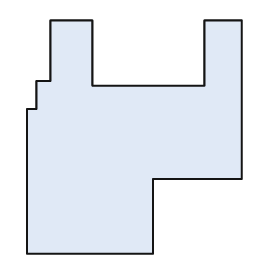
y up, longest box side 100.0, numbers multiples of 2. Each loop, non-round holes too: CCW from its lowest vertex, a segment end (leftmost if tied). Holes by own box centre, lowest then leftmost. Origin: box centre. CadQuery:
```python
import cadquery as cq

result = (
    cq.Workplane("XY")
    .moveTo(-46.0, -50.0)
    .lineTo(8.0, -50.0)
    .lineTo(8.0, -18.0)
    .lineTo(46.0, -18.0)
    .lineTo(46.0, 50.0)
    .lineTo(30.0, 50.0)
    .lineTo(30.0, 22.0)
    .lineTo(-18.0, 22.0)
    .lineTo(-18.0, 50.0)
    .lineTo(-36.0, 50.0)
    .lineTo(-36.0, 24.0)
    .lineTo(-42.0, 24.0)
    .lineTo(-42.0, 12.0)
    .lineTo(-46.0, 12.0)
    .close()
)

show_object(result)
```